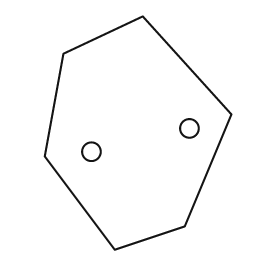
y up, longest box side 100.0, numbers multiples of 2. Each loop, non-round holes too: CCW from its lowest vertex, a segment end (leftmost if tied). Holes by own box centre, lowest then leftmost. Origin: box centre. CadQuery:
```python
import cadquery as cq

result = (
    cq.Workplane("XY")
    .moveTo(-10.0, -50.0)
    .lineTo(20.0, -40.0)
    .lineTo(40.0, 8.0)
    .lineTo(2.0, 50.0)
    .lineTo(-32.0, 34.0)
    .lineTo(-40.0, -10.0)
    .close()
    .moveTo(-20.0, -8.0)
    .circle(4.0)
    .moveTo(22.0, 2.0)
    .circle(4.0)
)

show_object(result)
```